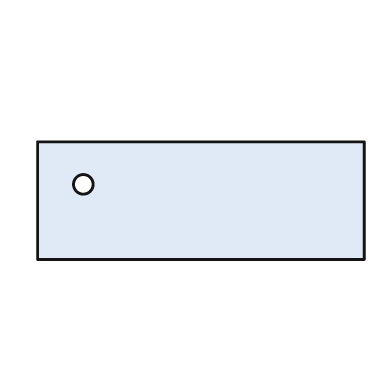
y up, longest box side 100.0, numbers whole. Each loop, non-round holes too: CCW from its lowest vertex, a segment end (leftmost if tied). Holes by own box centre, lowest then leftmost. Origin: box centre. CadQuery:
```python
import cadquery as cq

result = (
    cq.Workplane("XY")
    .moveTo(-50.0, -18.0)
    .lineTo(50.0, -18.0)
    .lineTo(50.0, 18.0)
    .lineTo(-50.0, 18.0)
    .close()
    .moveTo(-36.0, 5.0)
    .circle(3.0)
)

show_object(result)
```